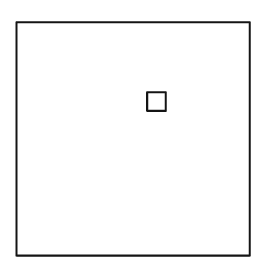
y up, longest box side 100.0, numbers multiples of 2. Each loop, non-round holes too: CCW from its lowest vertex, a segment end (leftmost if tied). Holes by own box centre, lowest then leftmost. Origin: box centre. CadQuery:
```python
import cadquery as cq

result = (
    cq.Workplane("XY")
    .moveTo(-50.0, -50.0)
    .lineTo(50.0, -50.0)
    .lineTo(50.0, 50.0)
    .lineTo(-50.0, 50.0)
    .close()
    .moveTo(6.0, 12.0)
    .lineTo(14.0, 12.0)
    .lineTo(14.0, 20.0)
    .lineTo(6.0, 20.0)
    .close()
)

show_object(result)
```